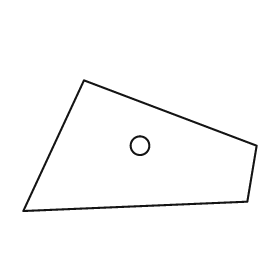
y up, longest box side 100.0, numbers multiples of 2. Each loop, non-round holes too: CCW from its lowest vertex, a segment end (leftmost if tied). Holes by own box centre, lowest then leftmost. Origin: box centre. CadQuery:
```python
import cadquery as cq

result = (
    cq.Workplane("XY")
    .moveTo(-50.0, -28.0)
    .lineTo(46.0, -24.0)
    .lineTo(50.0, 0.0)
    .lineTo(-24.0, 28.0)
    .close()
    .moveTo(0.0, 0.0)
    .circle(4.0)
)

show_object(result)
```